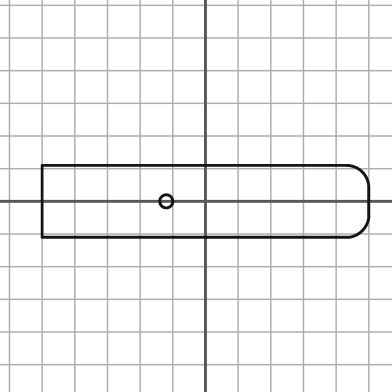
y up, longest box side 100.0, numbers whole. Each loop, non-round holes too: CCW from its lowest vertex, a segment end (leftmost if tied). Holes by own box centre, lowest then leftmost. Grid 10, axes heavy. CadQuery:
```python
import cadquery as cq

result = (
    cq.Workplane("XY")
    .moveTo(-50.0, -11.0)
    .lineTo(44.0, -11.0)
    .threePointArc((48.0, -9.0), (50.0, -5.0))
    .lineTo(50.0, 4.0)
    .threePointArc((48.0, 9.0), (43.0, 11.0))
    .lineTo(-50.0, 11.0)
    .close()
    .moveTo(-12.0, 0.0)
    .circle(2.0)
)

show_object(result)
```